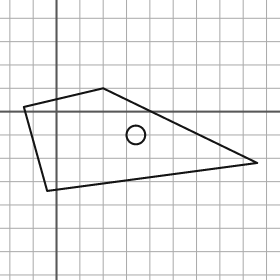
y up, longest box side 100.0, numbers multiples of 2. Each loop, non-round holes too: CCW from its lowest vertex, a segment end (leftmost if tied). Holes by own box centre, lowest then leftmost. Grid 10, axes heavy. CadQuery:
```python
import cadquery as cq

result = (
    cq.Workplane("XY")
    .moveTo(-4.0, -34.0)
    .lineTo(86.0, -22.0)
    .lineTo(20.0, 10.0)
    .lineTo(-14.0, 2.0)
    .close()
    .moveTo(34.0, -10.0)
    .circle(4.0)
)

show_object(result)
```